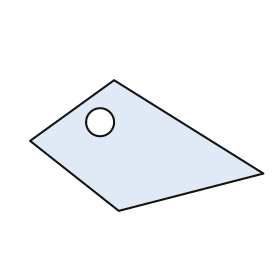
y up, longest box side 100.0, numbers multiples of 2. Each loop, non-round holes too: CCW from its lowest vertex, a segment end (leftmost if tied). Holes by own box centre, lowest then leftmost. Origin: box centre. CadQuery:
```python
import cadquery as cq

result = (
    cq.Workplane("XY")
    .moveTo(-12.0, -28.0)
    .lineTo(50.0, -12.0)
    .lineTo(-14.0, 28.0)
    .lineTo(-50.0, 2.0)
    .close()
    .moveTo(-20.0, 10.0)
    .circle(6.0)
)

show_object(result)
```